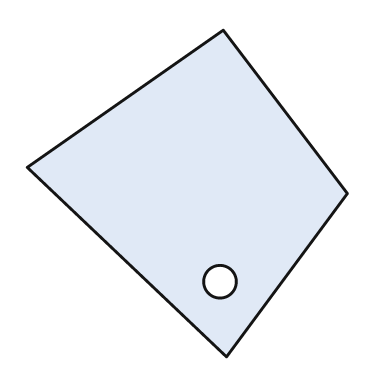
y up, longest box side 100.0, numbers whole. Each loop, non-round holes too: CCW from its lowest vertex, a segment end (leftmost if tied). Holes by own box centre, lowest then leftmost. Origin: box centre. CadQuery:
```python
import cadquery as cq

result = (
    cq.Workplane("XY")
    .moveTo(12.0, -50.0)
    .lineTo(49.0, 0.0)
    .lineTo(11.0, 50.0)
    .lineTo(-49.0, 8.0)
    .close()
    .moveTo(10.0, -27.0)
    .circle(5.0)
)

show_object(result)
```